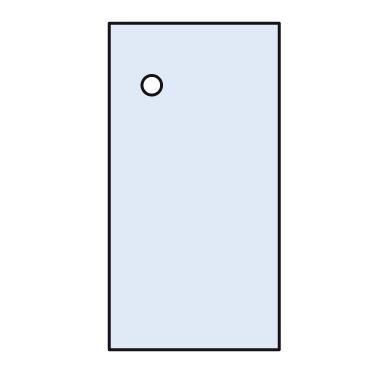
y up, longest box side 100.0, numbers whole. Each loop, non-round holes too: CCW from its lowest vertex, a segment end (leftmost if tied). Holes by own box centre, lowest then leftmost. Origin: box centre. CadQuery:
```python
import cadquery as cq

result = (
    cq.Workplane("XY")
    .moveTo(-26.0, -50.0)
    .lineTo(26.0, -50.0)
    .lineTo(26.0, 50.0)
    .lineTo(-26.0, 50.0)
    .close()
    .moveTo(-13.0, 31.0)
    .circle(3.0)
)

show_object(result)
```